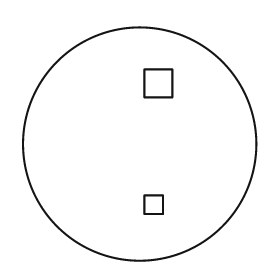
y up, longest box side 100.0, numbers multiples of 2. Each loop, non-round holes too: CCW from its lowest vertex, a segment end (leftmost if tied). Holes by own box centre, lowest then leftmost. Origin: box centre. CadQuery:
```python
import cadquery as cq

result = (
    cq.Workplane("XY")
    .moveTo(0.0, 0.0)
    .circle(50.0)
    .moveTo(2.0, -30.0)
    .lineTo(10.0, -30.0)
    .lineTo(10.0, -22.0)
    .lineTo(2.0, -22.0)
    .close()
    .moveTo(2.0, 20.0)
    .lineTo(14.0, 20.0)
    .lineTo(14.0, 32.0)
    .lineTo(2.0, 32.0)
    .close()
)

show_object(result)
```